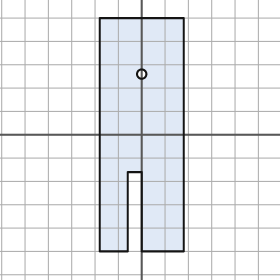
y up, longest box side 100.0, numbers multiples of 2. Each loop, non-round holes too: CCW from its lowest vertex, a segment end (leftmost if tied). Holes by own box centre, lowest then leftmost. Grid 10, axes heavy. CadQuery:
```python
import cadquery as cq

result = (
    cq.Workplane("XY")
    .moveTo(-18.0, -50.0)
    .lineTo(-6.0, -50.0)
    .lineTo(-6.0, -16.0)
    .lineTo(0.0, -16.0)
    .lineTo(0.0, -50.0)
    .lineTo(18.0, -50.0)
    .lineTo(18.0, 50.0)
    .lineTo(-18.0, 50.0)
    .close()
    .moveTo(0.0, 26.0)
    .circle(2.0)
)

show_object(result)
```